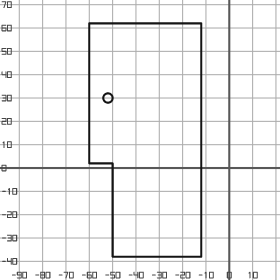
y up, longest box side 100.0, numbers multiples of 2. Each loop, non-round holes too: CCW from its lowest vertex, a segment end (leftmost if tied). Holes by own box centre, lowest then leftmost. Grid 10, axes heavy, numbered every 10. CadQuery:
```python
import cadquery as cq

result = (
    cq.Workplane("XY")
    .moveTo(-50.0, -38.0)
    .lineTo(-12.0, -38.0)
    .lineTo(-12.0, 62.0)
    .lineTo(-60.0, 62.0)
    .lineTo(-60.0, 2.0)
    .lineTo(-50.0, 2.0)
    .close()
    .moveTo(-52.0, 30.0)
    .circle(2.0)
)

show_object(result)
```